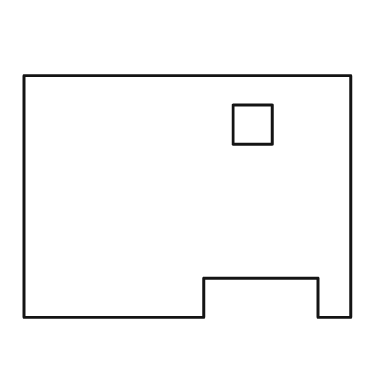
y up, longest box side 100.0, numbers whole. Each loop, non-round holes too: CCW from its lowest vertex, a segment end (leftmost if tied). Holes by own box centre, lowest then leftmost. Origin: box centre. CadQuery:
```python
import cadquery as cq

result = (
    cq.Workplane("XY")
    .moveTo(-50.0, -37.0)
    .lineTo(5.0, -37.0)
    .lineTo(5.0, -25.0)
    .lineTo(40.0, -25.0)
    .lineTo(40.0, -37.0)
    .lineTo(50.0, -37.0)
    .lineTo(50.0, 37.0)
    .lineTo(-50.0, 37.0)
    .close()
    .moveTo(14.0, 16.0)
    .lineTo(26.0, 16.0)
    .lineTo(26.0, 28.0)
    .lineTo(14.0, 28.0)
    .close()
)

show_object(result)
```